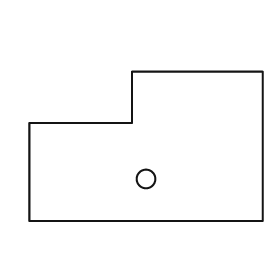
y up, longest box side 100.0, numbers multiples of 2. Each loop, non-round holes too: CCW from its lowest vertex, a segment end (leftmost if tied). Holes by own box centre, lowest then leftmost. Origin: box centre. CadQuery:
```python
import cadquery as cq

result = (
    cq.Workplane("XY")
    .moveTo(-50.0, -32.0)
    .lineTo(50.0, -32.0)
    .lineTo(50.0, 32.0)
    .lineTo(-6.0, 32.0)
    .lineTo(-6.0, 10.0)
    .lineTo(-50.0, 10.0)
    .close()
    .moveTo(0.0, -14.0)
    .circle(4.0)
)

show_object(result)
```